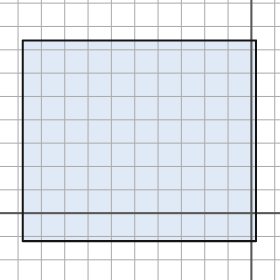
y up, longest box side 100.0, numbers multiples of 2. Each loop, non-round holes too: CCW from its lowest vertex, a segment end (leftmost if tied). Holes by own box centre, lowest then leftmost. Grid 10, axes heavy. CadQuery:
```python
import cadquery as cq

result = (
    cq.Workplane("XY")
    .moveTo(-98.0, -12.0)
    .lineTo(2.0, -12.0)
    .lineTo(2.0, 74.0)
    .lineTo(-98.0, 74.0)
    .close()
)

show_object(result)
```